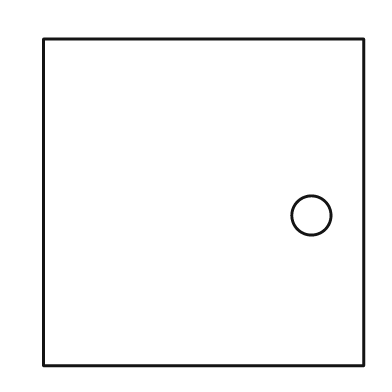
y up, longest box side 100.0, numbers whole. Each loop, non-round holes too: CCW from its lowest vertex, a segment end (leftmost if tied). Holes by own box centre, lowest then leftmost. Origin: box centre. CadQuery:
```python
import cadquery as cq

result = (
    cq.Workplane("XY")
    .moveTo(-49.0, -50.0)
    .lineTo(49.0, -50.0)
    .lineTo(49.0, 50.0)
    .lineTo(-49.0, 50.0)
    .close()
    .moveTo(33.0, -4.0)
    .circle(6.0)
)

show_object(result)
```